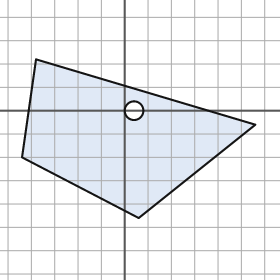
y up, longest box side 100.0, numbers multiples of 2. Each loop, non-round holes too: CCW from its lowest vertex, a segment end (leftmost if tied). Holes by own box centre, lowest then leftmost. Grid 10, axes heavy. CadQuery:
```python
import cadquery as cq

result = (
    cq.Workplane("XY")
    .moveTo(6.0, -46.0)
    .lineTo(56.0, -6.0)
    .lineTo(-38.0, 22.0)
    .lineTo(-44.0, -20.0)
    .close()
    .moveTo(4.0, 0.0)
    .circle(4.0)
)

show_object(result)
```